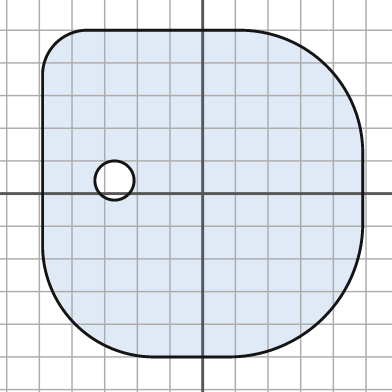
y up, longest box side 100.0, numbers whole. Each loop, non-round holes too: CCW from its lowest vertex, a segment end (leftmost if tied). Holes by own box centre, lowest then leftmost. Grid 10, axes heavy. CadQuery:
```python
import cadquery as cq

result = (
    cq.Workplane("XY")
    .moveTo(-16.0, -50.0)
    .lineTo(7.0, -50.0)
    .threePointArc((37.0, -38.0), (49.0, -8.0))
    .lineTo(49.0, 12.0)
    .threePointArc((38.0, 39.0), (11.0, 50.0))
    .lineTo(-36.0, 50.0)
    .threePointArc((-45.0, 46.0), (-49.0, 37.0))
    .lineTo(-49.0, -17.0)
    .threePointArc((-39.0, -40.0), (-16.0, -50.0))
    .close()
    .moveTo(-27.0, 4.0)
    .circle(6.0)
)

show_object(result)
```